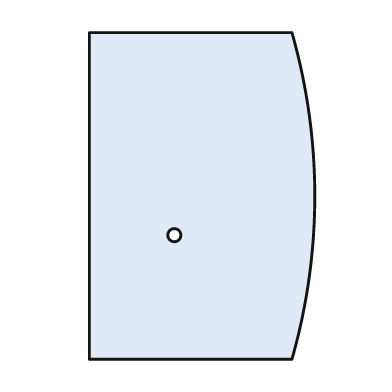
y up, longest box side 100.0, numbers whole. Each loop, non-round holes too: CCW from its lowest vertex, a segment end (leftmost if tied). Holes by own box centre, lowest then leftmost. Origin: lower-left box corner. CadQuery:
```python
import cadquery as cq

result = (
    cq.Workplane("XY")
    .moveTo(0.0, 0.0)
    .lineTo(62.0, 0.0)
    .threePointArc((69.0, 50.0), (62.0, 100.0))
    .lineTo(0.0, 100.0)
    .close()
    .moveTo(26.0, 38.0)
    .circle(2.0)
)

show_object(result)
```